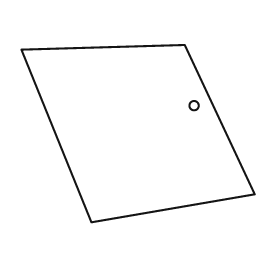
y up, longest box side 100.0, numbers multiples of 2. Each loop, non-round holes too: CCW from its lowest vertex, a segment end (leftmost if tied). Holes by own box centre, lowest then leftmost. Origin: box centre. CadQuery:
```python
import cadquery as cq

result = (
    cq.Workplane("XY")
    .moveTo(-20.0, -38.0)
    .lineTo(50.0, -26.0)
    .lineTo(20.0, 38.0)
    .lineTo(-50.0, 36.0)
    .close()
    .moveTo(24.0, 12.0)
    .circle(2.0)
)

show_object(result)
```